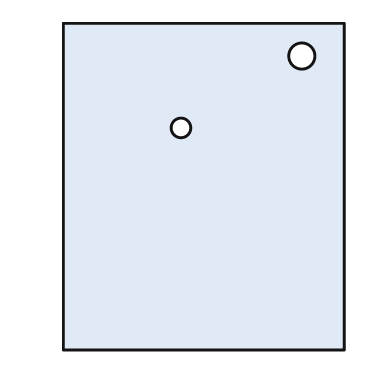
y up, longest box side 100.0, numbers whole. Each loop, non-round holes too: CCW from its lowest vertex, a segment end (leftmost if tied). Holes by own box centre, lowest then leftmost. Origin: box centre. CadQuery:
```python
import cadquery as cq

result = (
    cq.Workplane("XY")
    .moveTo(-43.0, -50.0)
    .lineTo(43.0, -50.0)
    .lineTo(43.0, 50.0)
    .lineTo(-43.0, 50.0)
    .close()
    .moveTo(-7.0, 18.0)
    .circle(3.0)
    .moveTo(30.0, 40.0)
    .circle(4.0)
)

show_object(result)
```